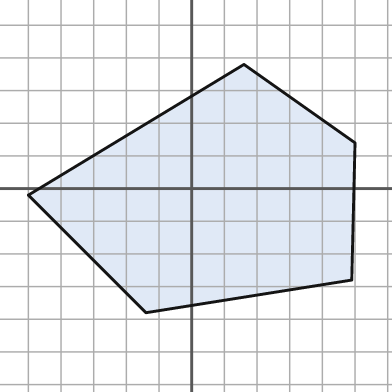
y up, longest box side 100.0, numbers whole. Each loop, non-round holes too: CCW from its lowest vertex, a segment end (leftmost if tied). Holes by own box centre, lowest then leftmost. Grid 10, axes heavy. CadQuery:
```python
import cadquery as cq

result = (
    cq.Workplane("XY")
    .moveTo(-14.0, -38.0)
    .lineTo(49.0, -28.0)
    .lineTo(50.0, 14.0)
    .lineTo(16.0, 38.0)
    .lineTo(-50.0, -2.0)
    .close()
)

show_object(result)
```